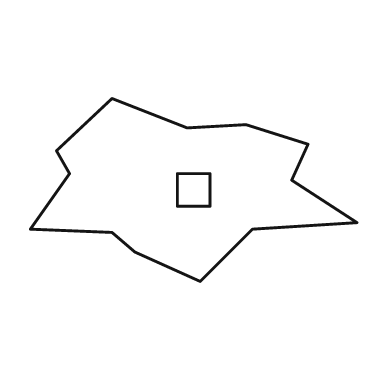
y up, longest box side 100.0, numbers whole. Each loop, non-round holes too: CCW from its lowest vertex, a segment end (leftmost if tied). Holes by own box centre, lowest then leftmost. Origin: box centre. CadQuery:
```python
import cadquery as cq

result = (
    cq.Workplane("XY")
    .moveTo(2.0, -28.0)
    .lineTo(18.0, -12.0)
    .lineTo(50.0, -10.0)
    .lineTo(30.0, 3.0)
    .lineTo(35.0, 14.0)
    .lineTo(16.0, 20.0)
    .lineTo(-2.0, 19.0)
    .lineTo(-25.0, 28.0)
    .lineTo(-42.0, 12.0)
    .lineTo(-38.0, 5.0)
    .lineTo(-50.0, -12.0)
    .lineTo(-25.0, -13.0)
    .lineTo(-18.0, -19.0)
    .close()
    .moveTo(-5.0, -5.0)
    .lineTo(5.0, -5.0)
    .lineTo(5.0, 5.0)
    .lineTo(-5.0, 5.0)
    .close()
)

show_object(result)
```